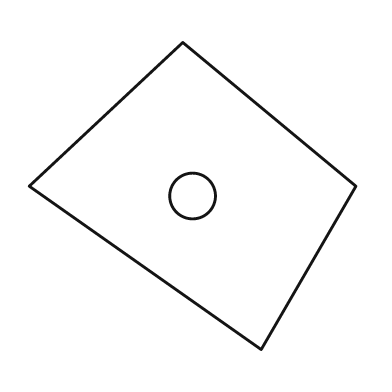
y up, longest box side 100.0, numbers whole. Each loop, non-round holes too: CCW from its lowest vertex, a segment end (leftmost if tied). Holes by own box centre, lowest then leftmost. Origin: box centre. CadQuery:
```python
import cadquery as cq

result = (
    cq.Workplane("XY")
    .moveTo(21.0, -47.0)
    .lineTo(50.0, 3.0)
    .lineTo(-3.0, 47.0)
    .lineTo(-50.0, 3.0)
    .close()
    .moveTo(0.0, 0.0)
    .circle(7.0)
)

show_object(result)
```